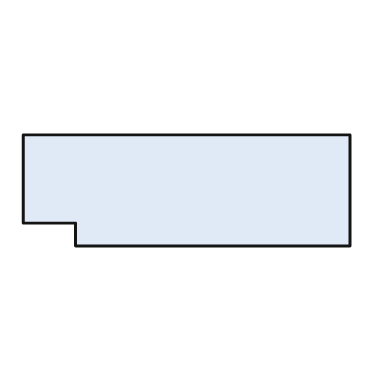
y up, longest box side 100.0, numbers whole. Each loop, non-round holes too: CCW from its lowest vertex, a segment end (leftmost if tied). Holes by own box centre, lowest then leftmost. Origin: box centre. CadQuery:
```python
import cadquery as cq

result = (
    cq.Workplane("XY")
    .moveTo(-34.0, -17.0)
    .lineTo(50.0, -17.0)
    .lineTo(50.0, 17.0)
    .lineTo(-50.0, 17.0)
    .lineTo(-50.0, -10.0)
    .lineTo(-34.0, -10.0)
    .close()
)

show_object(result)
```